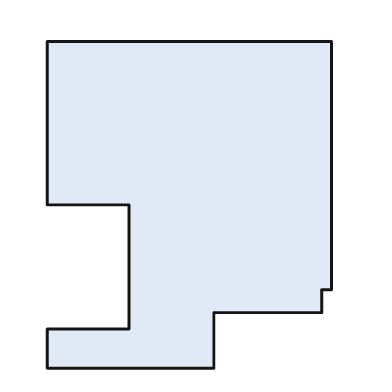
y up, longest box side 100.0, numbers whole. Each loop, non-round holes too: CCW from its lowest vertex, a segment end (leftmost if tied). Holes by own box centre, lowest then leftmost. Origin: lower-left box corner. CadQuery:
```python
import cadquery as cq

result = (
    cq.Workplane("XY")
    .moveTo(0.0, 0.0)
    .lineTo(51.0, 0.0)
    .lineTo(51.0, 17.0)
    .lineTo(84.0, 17.0)
    .lineTo(84.0, 24.0)
    .lineTo(87.0, 24.0)
    .lineTo(87.0, 100.0)
    .lineTo(0.0, 100.0)
    .lineTo(0.0, 50.0)
    .lineTo(25.0, 50.0)
    .lineTo(25.0, 12.0)
    .lineTo(0.0, 12.0)
    .close()
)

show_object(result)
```